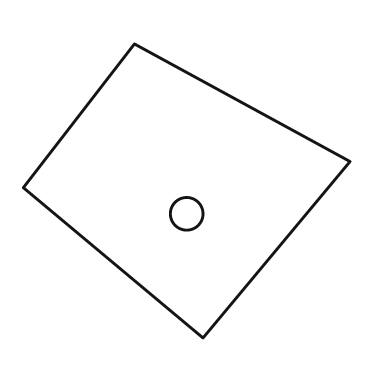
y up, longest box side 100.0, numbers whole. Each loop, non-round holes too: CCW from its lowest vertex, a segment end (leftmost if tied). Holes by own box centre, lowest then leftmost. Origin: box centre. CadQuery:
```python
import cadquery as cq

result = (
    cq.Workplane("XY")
    .moveTo(5.0, -45.0)
    .lineTo(50.0, 9.0)
    .lineTo(-16.0, 45.0)
    .lineTo(-50.0, 1.0)
    .close()
    .moveTo(0.0, -7.0)
    .circle(5.0)
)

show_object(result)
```